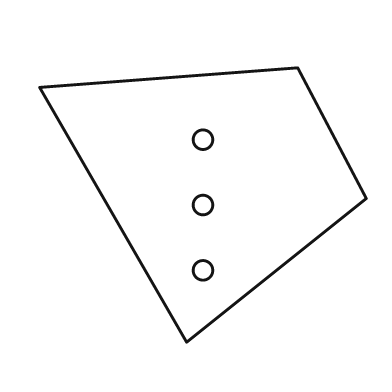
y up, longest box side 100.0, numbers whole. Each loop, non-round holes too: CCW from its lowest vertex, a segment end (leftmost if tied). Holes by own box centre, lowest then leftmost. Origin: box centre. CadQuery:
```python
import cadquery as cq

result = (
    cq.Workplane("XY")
    .moveTo(-5.0, -42.0)
    .lineTo(50.0, 2.0)
    .lineTo(29.0, 42.0)
    .lineTo(-50.0, 36.0)
    .close()
    .moveTo(0.0, -20.0)
    .circle(3.0)
    .moveTo(0.0, 0.0)
    .circle(3.0)
    .moveTo(0.0, 20.0)
    .circle(3.0)
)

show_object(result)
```